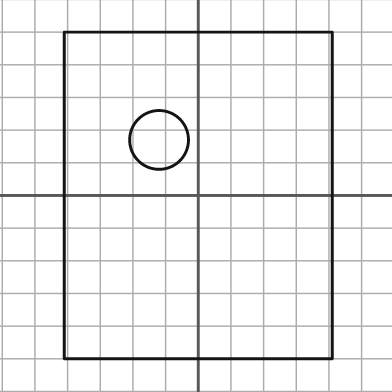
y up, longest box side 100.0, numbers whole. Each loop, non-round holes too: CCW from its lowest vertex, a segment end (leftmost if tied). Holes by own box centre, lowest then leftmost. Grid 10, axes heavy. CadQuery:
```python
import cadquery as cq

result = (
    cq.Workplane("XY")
    .moveTo(-41.0, -50.0)
    .lineTo(41.0, -50.0)
    .lineTo(41.0, 50.0)
    .lineTo(-41.0, 50.0)
    .close()
    .moveTo(-12.0, 17.0)
    .circle(9.0)
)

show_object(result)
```